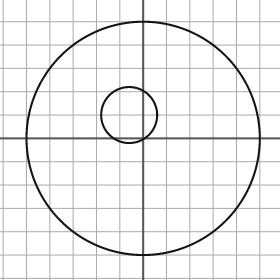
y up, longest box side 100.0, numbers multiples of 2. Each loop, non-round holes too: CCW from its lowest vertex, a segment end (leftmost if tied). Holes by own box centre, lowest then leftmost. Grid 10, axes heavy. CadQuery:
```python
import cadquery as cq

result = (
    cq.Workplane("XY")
    .moveTo(0.0, 0.0)
    .circle(50.0)
    .moveTo(-6.0, 10.0)
    .circle(12.0)
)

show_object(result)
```